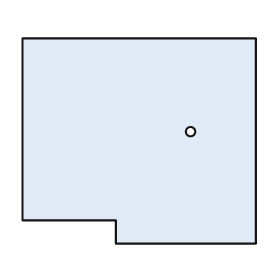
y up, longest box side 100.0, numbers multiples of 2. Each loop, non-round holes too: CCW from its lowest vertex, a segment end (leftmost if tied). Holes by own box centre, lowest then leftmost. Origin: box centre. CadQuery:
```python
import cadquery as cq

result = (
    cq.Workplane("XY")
    .moveTo(-10.0, -44.0)
    .lineTo(50.0, -44.0)
    .lineTo(50.0, 44.0)
    .lineTo(-50.0, 44.0)
    .lineTo(-50.0, -34.0)
    .lineTo(-10.0, -34.0)
    .close()
    .moveTo(22.0, 4.0)
    .circle(2.0)
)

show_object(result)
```